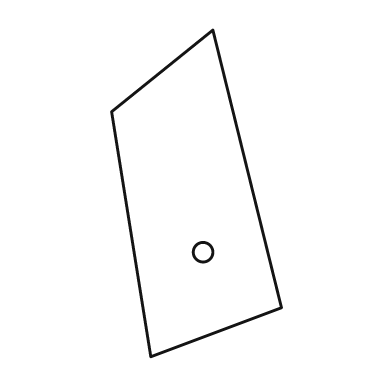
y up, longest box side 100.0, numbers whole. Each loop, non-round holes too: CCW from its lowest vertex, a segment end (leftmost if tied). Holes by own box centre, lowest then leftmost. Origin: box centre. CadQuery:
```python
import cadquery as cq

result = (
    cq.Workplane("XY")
    .moveTo(-14.0, -50.0)
    .lineTo(26.0, -35.0)
    .lineTo(5.0, 50.0)
    .lineTo(-26.0, 25.0)
    .close()
    .moveTo(2.0, -18.0)
    .circle(3.0)
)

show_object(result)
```